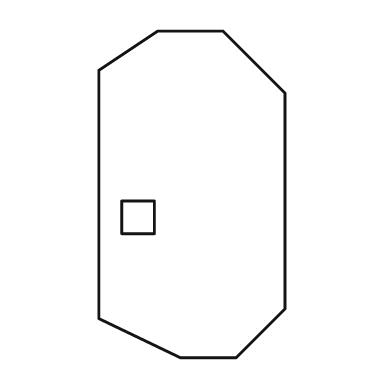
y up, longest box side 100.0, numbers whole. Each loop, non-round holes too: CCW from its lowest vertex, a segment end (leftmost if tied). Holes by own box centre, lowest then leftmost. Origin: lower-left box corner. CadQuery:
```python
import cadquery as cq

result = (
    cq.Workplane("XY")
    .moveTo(25.0, 0.0)
    .lineTo(42.0, 0.0)
    .lineTo(57.0, 15.0)
    .lineTo(57.0, 81.0)
    .lineTo(38.0, 100.0)
    .lineTo(18.0, 100.0)
    .lineTo(0.0, 88.0)
    .lineTo(0.0, 12.0)
    .close()
    .moveTo(7.0, 38.0)
    .lineTo(17.0, 38.0)
    .lineTo(17.0, 48.0)
    .lineTo(7.0, 48.0)
    .close()
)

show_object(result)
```